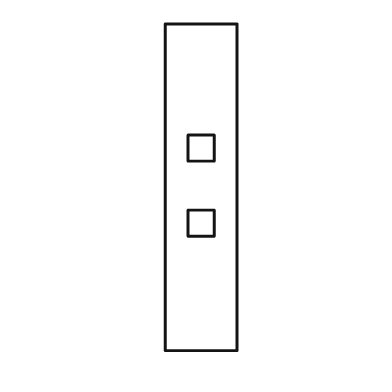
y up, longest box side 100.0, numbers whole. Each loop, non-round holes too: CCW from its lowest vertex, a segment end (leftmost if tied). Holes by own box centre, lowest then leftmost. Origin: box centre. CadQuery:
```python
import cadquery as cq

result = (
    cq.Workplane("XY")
    .moveTo(-11.0, -50.0)
    .lineTo(11.0, -50.0)
    .lineTo(11.0, 50.0)
    .lineTo(-11.0, 50.0)
    .close()
    .moveTo(-4.0, -15.0)
    .lineTo(4.0, -15.0)
    .lineTo(4.0, -7.0)
    .lineTo(-4.0, -7.0)
    .close()
    .moveTo(-4.0, 8.0)
    .lineTo(4.0, 8.0)
    .lineTo(4.0, 16.0)
    .lineTo(-4.0, 16.0)
    .close()
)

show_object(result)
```